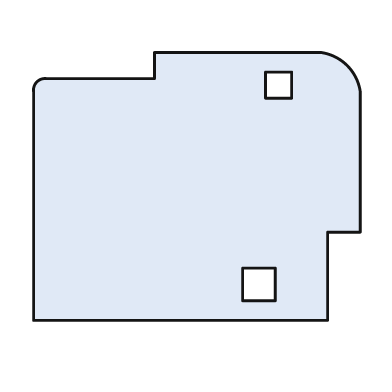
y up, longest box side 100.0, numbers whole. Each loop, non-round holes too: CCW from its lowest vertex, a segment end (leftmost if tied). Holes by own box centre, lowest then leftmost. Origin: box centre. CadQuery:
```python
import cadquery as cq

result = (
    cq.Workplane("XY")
    .moveTo(-50.0, -41.0)
    .lineTo(40.0, -41.0)
    .lineTo(40.0, -14.0)
    .lineTo(50.0, -14.0)
    .lineTo(50.0, 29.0)
    .threePointArc((46.0, 37.0), (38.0, 41.0))
    .lineTo(-13.0, 41.0)
    .lineTo(-13.0, 33.0)
    .lineTo(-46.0, 33.0)
    .threePointArc((-49.0, 32.0), (-50.0, 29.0))
    .close()
    .moveTo(14.0, -35.0)
    .lineTo(24.0, -35.0)
    .lineTo(24.0, -25.0)
    .lineTo(14.0, -25.0)
    .close()
    .moveTo(21.0, 27.0)
    .lineTo(29.0, 27.0)
    .lineTo(29.0, 35.0)
    .lineTo(21.0, 35.0)
    .close()
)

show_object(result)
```